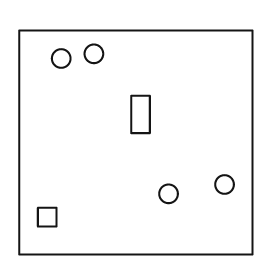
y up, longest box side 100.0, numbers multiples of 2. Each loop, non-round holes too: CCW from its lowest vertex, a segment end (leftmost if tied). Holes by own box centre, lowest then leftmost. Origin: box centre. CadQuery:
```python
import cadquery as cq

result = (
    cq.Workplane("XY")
    .moveTo(-50.0, -48.0)
    .lineTo(50.0, -48.0)
    .lineTo(50.0, 48.0)
    .lineTo(-50.0, 48.0)
    .close()
    .moveTo(-42.0, -36.0)
    .lineTo(-34.0, -36.0)
    .lineTo(-34.0, -28.0)
    .lineTo(-42.0, -28.0)
    .close()
    .moveTo(14.0, -22.0)
    .circle(4.0)
    .moveTo(38.0, -18.0)
    .circle(4.0)
    .moveTo(-2.0, 4.0)
    .lineTo(6.0, 4.0)
    .lineTo(6.0, 20.0)
    .lineTo(-2.0, 20.0)
    .close()
    .moveTo(-32.0, 36.0)
    .circle(4.0)
    .moveTo(-18.0, 38.0)
    .circle(4.0)
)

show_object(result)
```